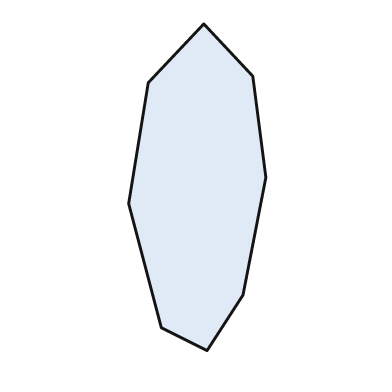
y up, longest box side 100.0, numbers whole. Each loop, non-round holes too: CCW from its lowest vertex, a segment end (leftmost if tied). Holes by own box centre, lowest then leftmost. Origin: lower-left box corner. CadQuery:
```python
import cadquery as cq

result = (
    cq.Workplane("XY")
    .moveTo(24.0, 0.0)
    .lineTo(35.0, 17.0)
    .lineTo(42.0, 53.0)
    .lineTo(38.0, 84.0)
    .lineTo(23.0, 100.0)
    .lineTo(6.0, 82.0)
    .lineTo(0.0, 45.0)
    .lineTo(10.0, 7.0)
    .close()
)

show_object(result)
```